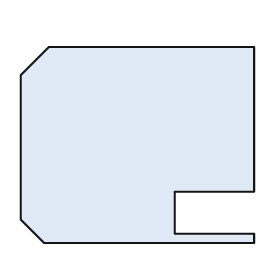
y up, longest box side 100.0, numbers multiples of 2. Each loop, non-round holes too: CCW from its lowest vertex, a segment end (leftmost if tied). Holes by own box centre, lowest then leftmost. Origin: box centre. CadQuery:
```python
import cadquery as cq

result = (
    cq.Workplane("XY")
    .moveTo(-40.0, -42.0)
    .lineTo(50.0, -42.0)
    .lineTo(50.0, -38.0)
    .lineTo(16.0, -38.0)
    .lineTo(16.0, -20.0)
    .lineTo(50.0, -20.0)
    .lineTo(50.0, 42.0)
    .lineTo(-38.0, 42.0)
    .lineTo(-50.0, 30.0)
    .lineTo(-50.0, -32.0)
    .close()
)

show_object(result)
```